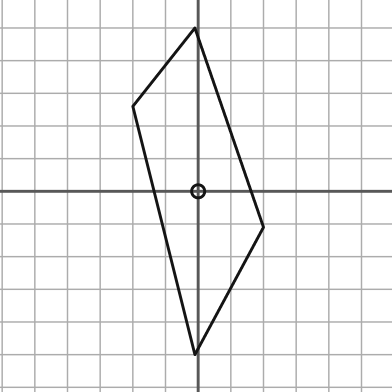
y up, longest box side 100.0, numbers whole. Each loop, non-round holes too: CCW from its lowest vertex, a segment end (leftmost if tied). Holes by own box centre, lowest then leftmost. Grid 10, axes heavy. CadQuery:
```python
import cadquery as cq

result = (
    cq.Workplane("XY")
    .moveTo(-1.0, -50.0)
    .lineTo(20.0, -11.0)
    .lineTo(-1.0, 50.0)
    .lineTo(-20.0, 26.0)
    .close()
    .moveTo(0.0, 0.0)
    .circle(2.0)
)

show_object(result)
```